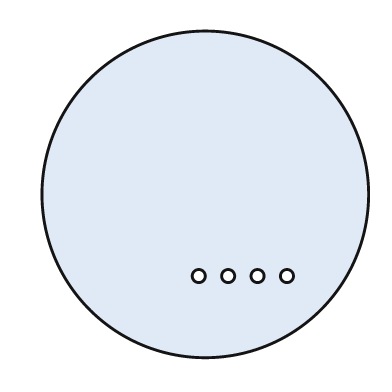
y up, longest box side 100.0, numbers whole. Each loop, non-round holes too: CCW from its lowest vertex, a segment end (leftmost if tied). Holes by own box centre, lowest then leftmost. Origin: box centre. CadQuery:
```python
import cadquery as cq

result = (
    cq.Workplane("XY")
    .moveTo(0.0, 0.0)
    .circle(50.0)
    .moveTo(-2.0, -25.0)
    .circle(2.0)
    .moveTo(7.0, -25.0)
    .circle(2.0)
    .moveTo(16.0, -25.0)
    .circle(2.0)
    .moveTo(25.0, -25.0)
    .circle(2.0)
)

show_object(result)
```